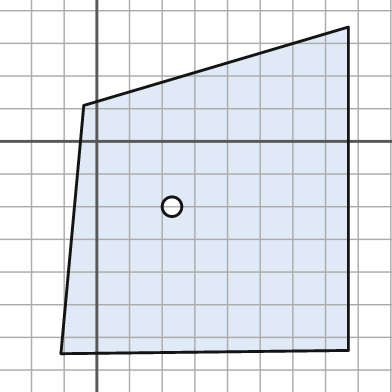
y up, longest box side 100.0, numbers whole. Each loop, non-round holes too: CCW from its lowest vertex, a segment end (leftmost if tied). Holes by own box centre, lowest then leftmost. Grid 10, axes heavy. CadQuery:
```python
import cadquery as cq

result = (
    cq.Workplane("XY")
    .moveTo(-11.0, -65.0)
    .lineTo(77.0, -64.0)
    .lineTo(77.0, 35.0)
    .lineTo(-4.0, 11.0)
    .close()
    .moveTo(23.0, -20.0)
    .circle(3.0)
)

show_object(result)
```